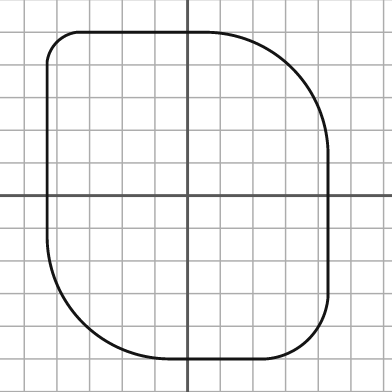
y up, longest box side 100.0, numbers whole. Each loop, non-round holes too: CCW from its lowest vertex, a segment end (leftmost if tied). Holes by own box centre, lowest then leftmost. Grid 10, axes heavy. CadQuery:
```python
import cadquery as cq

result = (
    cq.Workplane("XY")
    .moveTo(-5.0, -50.0)
    .lineTo(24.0, -50.0)
    .threePointArc((37.0, -44.0), (43.0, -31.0))
    .lineTo(43.0, 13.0)
    .threePointArc((32.0, 39.0), (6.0, 50.0))
    .lineTo(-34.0, 50.0)
    .threePointArc((-40.0, 47.0), (-43.0, 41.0))
    .lineTo(-43.0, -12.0)
    .threePointArc((-32.0, -39.0), (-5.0, -50.0))
    .close()
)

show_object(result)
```